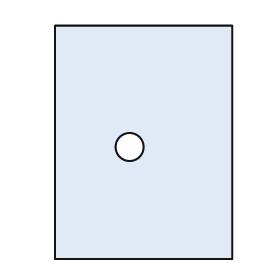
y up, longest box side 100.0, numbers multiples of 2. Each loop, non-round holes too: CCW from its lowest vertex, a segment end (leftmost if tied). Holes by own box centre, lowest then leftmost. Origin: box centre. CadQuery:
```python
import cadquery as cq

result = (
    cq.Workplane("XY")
    .moveTo(-38.0, -50.0)
    .lineTo(38.0, -50.0)
    .lineTo(38.0, 50.0)
    .lineTo(-38.0, 50.0)
    .close()
    .moveTo(-6.0, -2.0)
    .circle(6.0)
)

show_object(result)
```